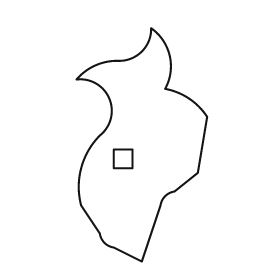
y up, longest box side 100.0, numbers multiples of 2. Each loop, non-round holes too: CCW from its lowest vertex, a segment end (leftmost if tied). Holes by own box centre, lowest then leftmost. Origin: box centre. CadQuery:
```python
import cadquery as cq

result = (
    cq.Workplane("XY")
    .moveTo(0.0, -50.0)
    .lineTo(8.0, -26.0)
    .threePointArc((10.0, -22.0), (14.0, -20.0))
    .lineTo(24.0, -12.0)
    .lineTo(28.0, 12.0)
    .threePointArc((20.0, 20.0), (10.0, 24.0))
    .threePointArc((12.0, 38.0), (4.0, 50.0))
    .threePointArc((0.0, 40.0), (-10.0, 36.0))
    .threePointArc((-20.0, 34.0), (-28.0, 28.0))
    .threePointArc((-14.0, 20.0), (-18.0, 4.0))
    .threePointArc((-26.0, -10.0), (-26.0, -26.0))
    .lineTo(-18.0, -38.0)
    .threePointArc((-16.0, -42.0), (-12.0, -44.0))
    .close()
    .moveTo(-12.0, -10.0)
    .lineTo(-4.0, -10.0)
    .lineTo(-4.0, -2.0)
    .lineTo(-12.0, -2.0)
    .close()
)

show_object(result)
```